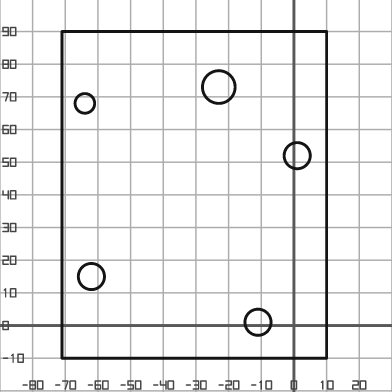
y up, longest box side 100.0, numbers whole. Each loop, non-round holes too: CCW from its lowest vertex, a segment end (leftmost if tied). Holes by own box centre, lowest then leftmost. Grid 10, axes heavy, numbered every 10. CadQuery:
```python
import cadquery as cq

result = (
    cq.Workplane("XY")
    .moveTo(-71.0, -10.0)
    .lineTo(10.0, -10.0)
    .lineTo(10.0, 90.0)
    .lineTo(-71.0, 90.0)
    .close()
    .moveTo(-11.0, 1.0)
    .circle(4.0)
    .moveTo(-62.0, 15.0)
    .circle(4.0)
    .moveTo(1.0, 52.0)
    .circle(4.0)
    .moveTo(-64.0, 68.0)
    .circle(3.0)
    .moveTo(-23.0, 73.0)
    .circle(5.0)
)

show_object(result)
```